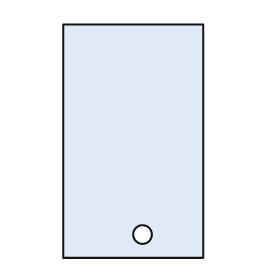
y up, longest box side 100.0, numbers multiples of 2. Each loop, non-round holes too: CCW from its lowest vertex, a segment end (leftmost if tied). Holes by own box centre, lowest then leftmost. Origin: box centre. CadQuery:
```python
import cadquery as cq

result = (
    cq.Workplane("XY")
    .moveTo(-30.0, -50.0)
    .lineTo(30.0, -50.0)
    .lineTo(30.0, 50.0)
    .lineTo(-30.0, 50.0)
    .close()
    .moveTo(4.0, -40.0)
    .circle(4.0)
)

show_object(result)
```